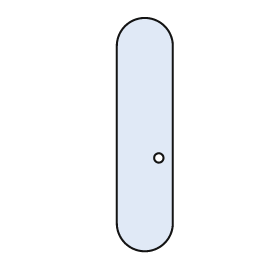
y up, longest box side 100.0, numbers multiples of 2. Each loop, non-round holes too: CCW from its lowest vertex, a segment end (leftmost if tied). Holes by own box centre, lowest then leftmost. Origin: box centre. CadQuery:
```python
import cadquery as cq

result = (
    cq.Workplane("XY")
    .moveTo(-12.0, -38.0)
    .threePointArc((0.0, -50.0), (12.0, -38.0))
    .lineTo(12.0, 38.0)
    .threePointArc((0.0, 50.0), (-12.0, 38.0))
    .close()
    .moveTo(6.0, -10.0)
    .circle(2.0)
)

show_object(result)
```